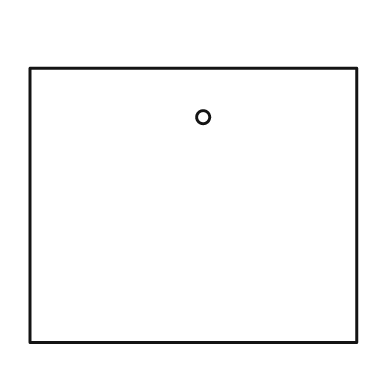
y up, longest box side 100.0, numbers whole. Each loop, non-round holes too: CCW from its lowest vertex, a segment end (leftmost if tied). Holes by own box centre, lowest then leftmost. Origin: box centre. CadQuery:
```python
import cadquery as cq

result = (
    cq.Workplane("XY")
    .moveTo(-50.0, -42.0)
    .lineTo(50.0, -42.0)
    .lineTo(50.0, 42.0)
    .lineTo(-50.0, 42.0)
    .close()
    .moveTo(3.0, 27.0)
    .circle(2.0)
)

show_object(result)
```